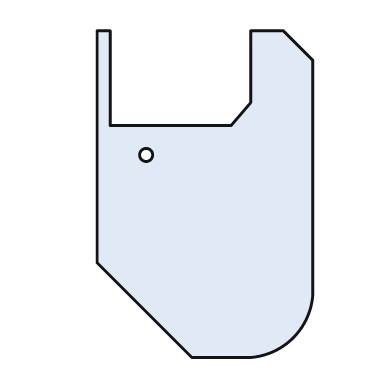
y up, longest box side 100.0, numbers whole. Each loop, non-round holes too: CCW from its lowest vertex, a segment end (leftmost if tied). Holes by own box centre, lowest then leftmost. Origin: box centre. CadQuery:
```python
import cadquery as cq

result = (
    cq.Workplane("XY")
    .moveTo(-4.0, -50.0)
    .lineTo(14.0, -50.0)
    .threePointArc((27.0, -44.0), (33.0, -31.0))
    .lineTo(33.0, 41.0)
    .lineTo(24.0, 50.0)
    .lineTo(14.0, 50.0)
    .lineTo(14.0, 28.0)
    .lineTo(8.0, 21.0)
    .lineTo(-29.0, 21.0)
    .lineTo(-29.0, 50.0)
    .lineTo(-33.0, 50.0)
    .lineTo(-33.0, -21.0)
    .close()
    .moveTo(-18.0, 12.0)
    .circle(2.0)
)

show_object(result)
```